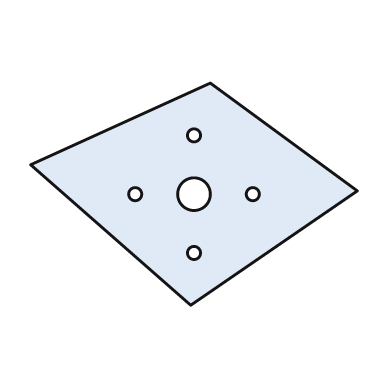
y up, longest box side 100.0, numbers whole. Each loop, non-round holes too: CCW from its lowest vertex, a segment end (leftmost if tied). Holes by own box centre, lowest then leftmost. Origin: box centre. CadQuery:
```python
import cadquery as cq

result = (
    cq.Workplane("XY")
    .moveTo(-1.0, -34.0)
    .lineTo(50.0, 1.0)
    .lineTo(5.0, 34.0)
    .lineTo(-50.0, 9.0)
    .close()
    .moveTo(0.0, -18.0)
    .circle(2.0)
    .moveTo(-18.0, 0.0)
    .circle(2.0)
    .moveTo(0.0, 0.0)
    .circle(5.0)
    .moveTo(18.0, 0.0)
    .circle(2.0)
    .moveTo(0.0, 18.0)
    .circle(2.0)
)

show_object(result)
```